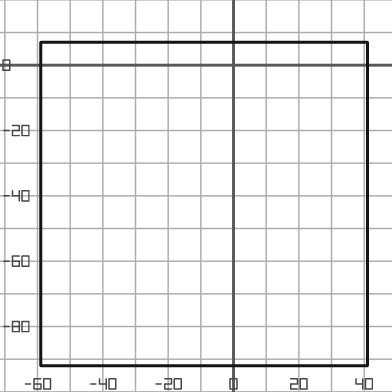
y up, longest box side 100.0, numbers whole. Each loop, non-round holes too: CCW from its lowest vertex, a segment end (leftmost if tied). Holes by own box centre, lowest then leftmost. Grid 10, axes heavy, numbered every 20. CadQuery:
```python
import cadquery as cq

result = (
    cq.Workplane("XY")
    .moveTo(-59.0, -92.0)
    .lineTo(41.0, -92.0)
    .lineTo(41.0, 7.0)
    .lineTo(-59.0, 7.0)
    .close()
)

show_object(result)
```